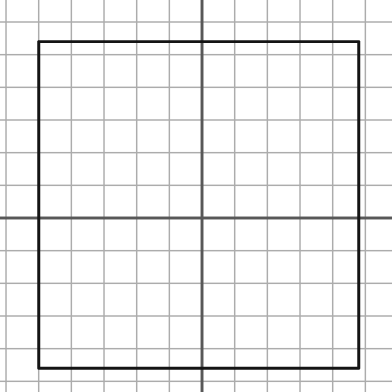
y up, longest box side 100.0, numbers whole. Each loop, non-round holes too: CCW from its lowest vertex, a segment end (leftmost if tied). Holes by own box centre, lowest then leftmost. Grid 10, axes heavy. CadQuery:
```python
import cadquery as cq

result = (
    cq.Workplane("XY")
    .moveTo(-50.0, -46.0)
    .lineTo(48.0, -46.0)
    .lineTo(48.0, 54.0)
    .lineTo(-50.0, 54.0)
    .close()
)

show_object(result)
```